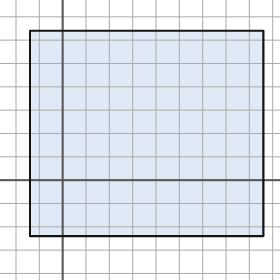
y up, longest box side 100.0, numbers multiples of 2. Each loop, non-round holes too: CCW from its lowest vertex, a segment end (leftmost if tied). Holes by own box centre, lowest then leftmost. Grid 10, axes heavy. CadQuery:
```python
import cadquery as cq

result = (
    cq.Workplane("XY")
    .moveTo(-14.0, -24.0)
    .lineTo(86.0, -24.0)
    .lineTo(86.0, 64.0)
    .lineTo(-14.0, 64.0)
    .close()
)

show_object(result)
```